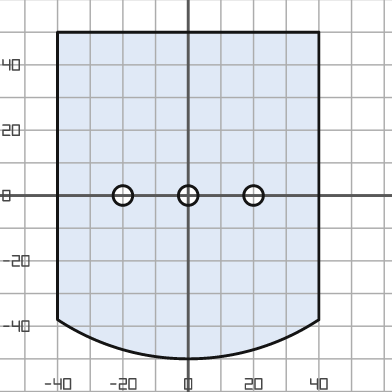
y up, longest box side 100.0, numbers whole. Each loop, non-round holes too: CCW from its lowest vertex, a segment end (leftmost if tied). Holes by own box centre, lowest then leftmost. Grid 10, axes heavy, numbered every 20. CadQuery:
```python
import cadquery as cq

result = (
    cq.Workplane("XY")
    .moveTo(-40.0, -38.0)
    .threePointArc((0.0, -50.0), (40.0, -38.0))
    .lineTo(40.0, 50.0)
    .lineTo(-40.0, 50.0)
    .close()
    .moveTo(-20.0, 0.0)
    .circle(3.0)
    .moveTo(0.0, 0.0)
    .circle(3.0)
    .moveTo(20.0, 0.0)
    .circle(3.0)
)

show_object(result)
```